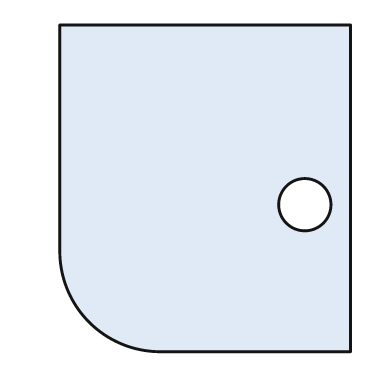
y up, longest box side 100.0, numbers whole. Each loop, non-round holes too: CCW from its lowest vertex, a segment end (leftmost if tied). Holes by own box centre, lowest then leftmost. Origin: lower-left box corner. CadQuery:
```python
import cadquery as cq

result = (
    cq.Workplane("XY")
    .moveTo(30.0, 0.0)
    .lineTo(89.0, 0.0)
    .lineTo(89.0, 100.0)
    .lineTo(0.0, 100.0)
    .lineTo(0.0, 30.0)
    .threePointArc((9.0, 9.0), (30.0, 0.0))
    .close()
    .moveTo(75.0, 45.0)
    .circle(8.0)
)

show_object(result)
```